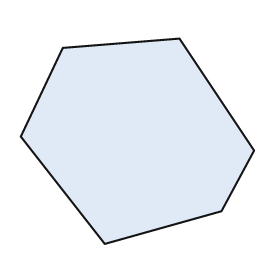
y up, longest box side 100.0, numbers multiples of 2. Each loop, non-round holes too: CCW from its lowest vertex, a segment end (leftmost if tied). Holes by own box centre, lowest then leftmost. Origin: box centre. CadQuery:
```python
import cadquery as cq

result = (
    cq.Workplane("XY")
    .moveTo(-14.0, -44.0)
    .lineTo(36.0, -30.0)
    .lineTo(50.0, -4.0)
    .lineTo(18.0, 44.0)
    .lineTo(-32.0, 40.0)
    .lineTo(-50.0, 2.0)
    .close()
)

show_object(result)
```